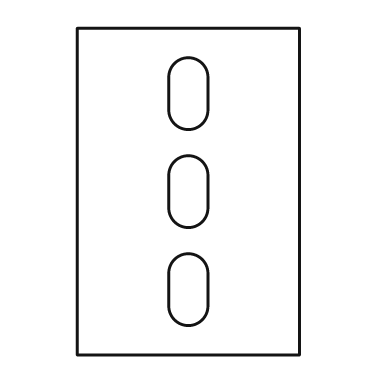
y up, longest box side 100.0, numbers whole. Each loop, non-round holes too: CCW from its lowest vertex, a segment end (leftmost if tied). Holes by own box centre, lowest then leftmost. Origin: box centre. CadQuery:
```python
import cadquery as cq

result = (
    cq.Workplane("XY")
    .moveTo(-34.0, -50.0)
    .lineTo(34.0, -50.0)
    .lineTo(34.0, 50.0)
    .lineTo(-34.0, 50.0)
    .close()
    .moveTo(-6.0, -35.0)
    .threePointArc((0.0, -41.0), (6.0, -35.0))
    .lineTo(6.0, -25.0)
    .threePointArc((0.0, -19.0), (-6.0, -25.0))
    .close()
    .moveTo(-6.0, -5.0)
    .threePointArc((0.0, -11.0), (6.0, -5.0))
    .lineTo(6.0, 5.0)
    .threePointArc((0.0, 11.0), (-6.0, 5.0))
    .close()
    .moveTo(-6.0, 25.0)
    .threePointArc((0.0, 19.0), (6.0, 25.0))
    .lineTo(6.0, 35.0)
    .threePointArc((0.0, 41.0), (-6.0, 35.0))
    .close()
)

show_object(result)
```